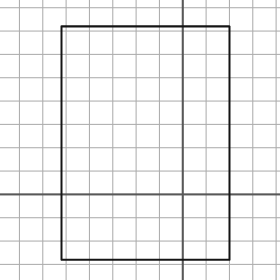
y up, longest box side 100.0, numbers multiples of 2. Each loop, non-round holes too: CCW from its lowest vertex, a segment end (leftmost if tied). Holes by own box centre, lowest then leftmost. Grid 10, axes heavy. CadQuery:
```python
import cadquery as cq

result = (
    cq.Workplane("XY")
    .moveTo(-52.0, -28.0)
    .lineTo(20.0, -28.0)
    .lineTo(20.0, 72.0)
    .lineTo(-52.0, 72.0)
    .close()
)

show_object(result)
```